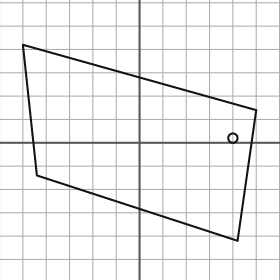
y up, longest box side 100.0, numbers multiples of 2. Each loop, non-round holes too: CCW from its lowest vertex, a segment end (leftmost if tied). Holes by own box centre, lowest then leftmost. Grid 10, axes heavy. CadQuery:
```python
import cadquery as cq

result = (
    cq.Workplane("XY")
    .moveTo(42.0, -42.0)
    .lineTo(50.0, 14.0)
    .lineTo(-50.0, 42.0)
    .lineTo(-44.0, -14.0)
    .close()
    .moveTo(40.0, 2.0)
    .circle(2.0)
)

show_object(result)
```